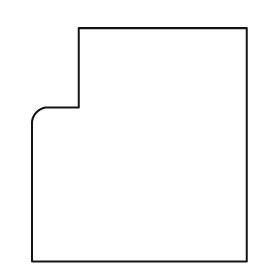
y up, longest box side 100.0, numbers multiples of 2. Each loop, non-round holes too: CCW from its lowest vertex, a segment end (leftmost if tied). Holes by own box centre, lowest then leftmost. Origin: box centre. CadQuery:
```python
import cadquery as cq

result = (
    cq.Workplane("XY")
    .moveTo(-46.0, -50.0)
    .lineTo(46.0, -50.0)
    .lineTo(46.0, 50.0)
    .lineTo(-26.0, 50.0)
    .lineTo(-26.0, 16.0)
    .lineTo(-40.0, 16.0)
    .threePointArc((-44.0, 14.0), (-46.0, 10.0))
    .close()
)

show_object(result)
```